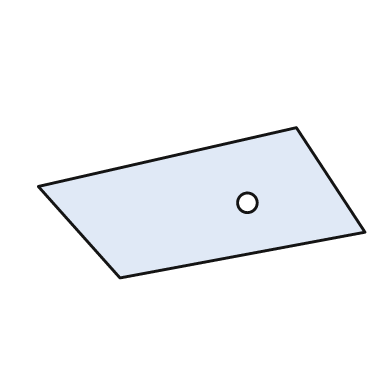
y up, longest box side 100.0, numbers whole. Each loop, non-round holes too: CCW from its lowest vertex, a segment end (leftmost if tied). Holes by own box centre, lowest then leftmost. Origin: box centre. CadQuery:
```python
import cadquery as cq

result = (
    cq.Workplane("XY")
    .moveTo(-25.0, -23.0)
    .lineTo(50.0, -9.0)
    .lineTo(29.0, 23.0)
    .lineTo(-50.0, 5.0)
    .close()
    .moveTo(14.0, 0.0)
    .circle(3.0)
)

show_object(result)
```